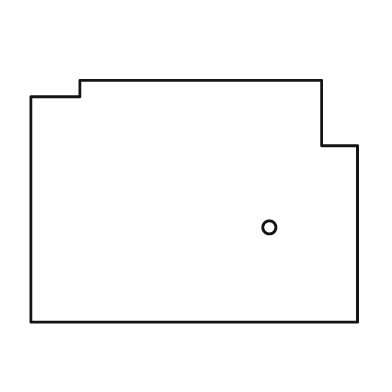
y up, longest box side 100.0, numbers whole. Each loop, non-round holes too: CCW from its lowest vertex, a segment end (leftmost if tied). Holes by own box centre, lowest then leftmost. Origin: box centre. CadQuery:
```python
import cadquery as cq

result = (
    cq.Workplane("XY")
    .moveTo(-50.0, -37.0)
    .lineTo(50.0, -37.0)
    .lineTo(50.0, 17.0)
    .lineTo(39.0, 17.0)
    .lineTo(39.0, 37.0)
    .lineTo(-35.0, 37.0)
    .lineTo(-35.0, 32.0)
    .lineTo(-50.0, 32.0)
    .close()
    .moveTo(23.0, -8.0)
    .circle(2.0)
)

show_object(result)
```